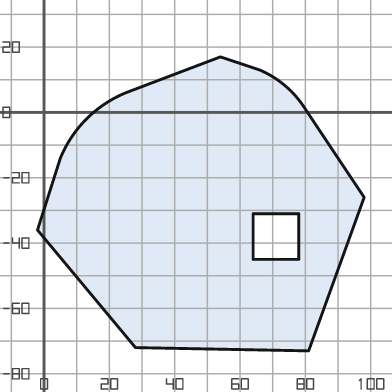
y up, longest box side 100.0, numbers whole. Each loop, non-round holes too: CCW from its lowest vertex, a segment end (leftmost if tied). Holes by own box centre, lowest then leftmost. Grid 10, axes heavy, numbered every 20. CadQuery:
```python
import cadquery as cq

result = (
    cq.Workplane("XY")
    .moveTo(81.0, -73.0)
    .lineTo(98.0, -26.0)
    .lineTo(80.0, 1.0)
    .threePointArc((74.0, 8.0), (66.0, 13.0))
    .lineTo(54.0, 17.0)
    .lineTo(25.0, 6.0)
    .threePointArc((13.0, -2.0), (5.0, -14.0))
    .lineTo(-2.0, -36.0)
    .lineTo(28.0, -72.0)
    .close()
    .moveTo(64.0, -45.0)
    .lineTo(78.0, -45.0)
    .lineTo(78.0, -31.0)
    .lineTo(64.0, -31.0)
    .close()
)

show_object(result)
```